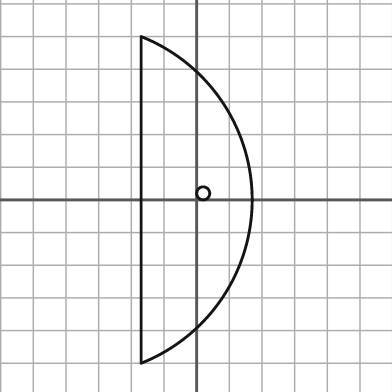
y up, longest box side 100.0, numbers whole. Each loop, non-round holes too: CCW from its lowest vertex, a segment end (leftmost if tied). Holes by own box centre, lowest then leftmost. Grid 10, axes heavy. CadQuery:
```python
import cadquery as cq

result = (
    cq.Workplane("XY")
    .moveTo(-17.0, -50.0)
    .threePointArc((17.0, 0.0), (-17.0, 50.0))
    .close()
    .moveTo(2.0, 2.0)
    .circle(2.0)
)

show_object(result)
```